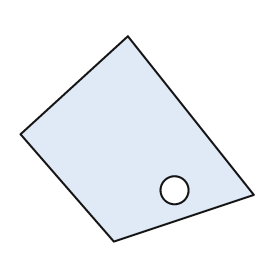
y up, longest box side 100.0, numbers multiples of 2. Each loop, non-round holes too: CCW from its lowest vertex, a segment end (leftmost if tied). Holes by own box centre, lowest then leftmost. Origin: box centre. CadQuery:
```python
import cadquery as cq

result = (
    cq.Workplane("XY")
    .moveTo(-10.0, -44.0)
    .lineTo(50.0, -24.0)
    .lineTo(-4.0, 44.0)
    .lineTo(-50.0, 2.0)
    .close()
    .moveTo(16.0, -22.0)
    .circle(6.0)
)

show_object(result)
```